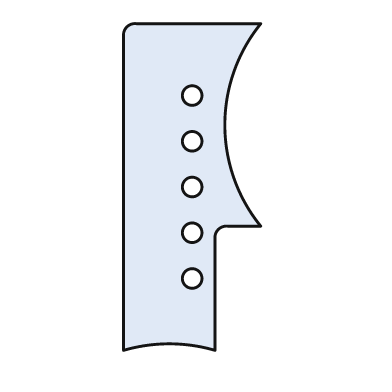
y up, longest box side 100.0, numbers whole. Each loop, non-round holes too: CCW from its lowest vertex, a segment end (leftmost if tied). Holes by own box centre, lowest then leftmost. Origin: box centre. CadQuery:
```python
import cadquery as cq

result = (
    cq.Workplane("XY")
    .moveTo(-21.0, -50.0)
    .threePointArc((-7.0, -48.0), (7.0, -50.0))
    .lineTo(7.0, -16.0)
    .threePointArc((8.0, -13.0), (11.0, -12.0))
    .lineTo(21.0, -12.0)
    .threePointArc((10.0, 19.0), (21.0, 50.0))
    .lineTo(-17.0, 50.0)
    .threePointArc((-20.0, 49.0), (-21.0, 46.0))
    .close()
    .moveTo(0.0, -28.0)
    .circle(3.0)
    .moveTo(0.0, -14.0)
    .circle(3.0)
    .moveTo(0.0, 0.0)
    .circle(3.0)
    .moveTo(0.0, 14.0)
    .circle(3.0)
    .moveTo(0.0, 28.0)
    .circle(3.0)
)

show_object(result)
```